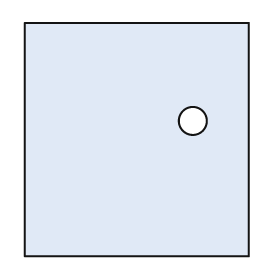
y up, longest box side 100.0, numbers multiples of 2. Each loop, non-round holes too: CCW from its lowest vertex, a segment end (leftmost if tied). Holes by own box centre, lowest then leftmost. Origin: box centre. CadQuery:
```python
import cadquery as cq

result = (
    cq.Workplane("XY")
    .moveTo(-48.0, -50.0)
    .lineTo(48.0, -50.0)
    .lineTo(48.0, 50.0)
    .lineTo(-48.0, 50.0)
    .close()
    .moveTo(24.0, 8.0)
    .circle(6.0)
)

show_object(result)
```